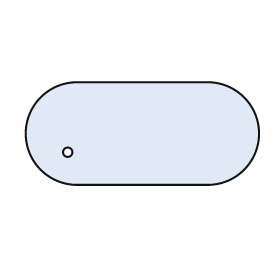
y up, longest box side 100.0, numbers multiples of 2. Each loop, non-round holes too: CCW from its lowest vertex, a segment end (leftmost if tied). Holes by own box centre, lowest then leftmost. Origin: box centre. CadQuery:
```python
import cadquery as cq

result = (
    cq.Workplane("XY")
    .moveTo(-28.0, -22.0)
    .lineTo(28.0, -22.0)
    .threePointArc((50.0, 0.0), (28.0, 22.0))
    .lineTo(-28.0, 22.0)
    .threePointArc((-50.0, 0.0), (-28.0, -22.0))
    .close()
    .moveTo(-32.0, -8.0)
    .circle(2.0)
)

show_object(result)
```